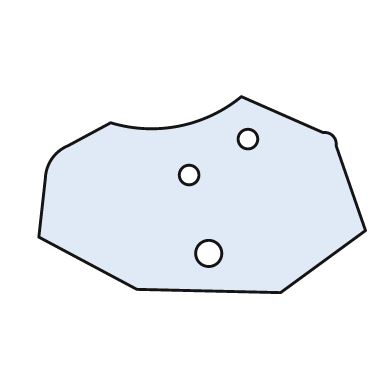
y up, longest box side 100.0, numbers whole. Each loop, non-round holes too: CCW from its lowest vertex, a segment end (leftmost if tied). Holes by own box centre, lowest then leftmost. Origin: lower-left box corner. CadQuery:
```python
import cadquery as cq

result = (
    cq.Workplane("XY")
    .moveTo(74.0, 0.0)
    .lineTo(100.0, 19.0)
    .lineTo(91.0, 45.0)
    .threePointArc((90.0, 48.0), (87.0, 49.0))
    .lineTo(62.0, 60.0)
    .threePointArc((43.0, 51.0), (22.0, 52.0))
    .lineTo(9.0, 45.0)
    .threePointArc((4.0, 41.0), (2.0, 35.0))
    .lineTo(0.0, 17.0)
    .lineTo(30.0, 1.0)
    .close()
    .moveTo(52.0, 12.0)
    .circle(4.0)
    .moveTo(46.0, 36.0)
    .circle(3.0)
    .moveTo(64.0, 47.0)
    .circle(3.0)
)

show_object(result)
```